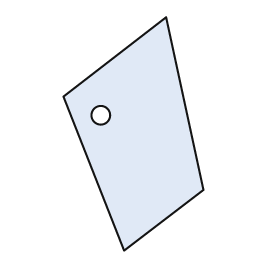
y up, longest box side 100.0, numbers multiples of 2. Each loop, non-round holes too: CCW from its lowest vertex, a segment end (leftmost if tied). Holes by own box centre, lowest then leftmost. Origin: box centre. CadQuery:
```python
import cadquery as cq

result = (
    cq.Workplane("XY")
    .moveTo(-4.0, -50.0)
    .lineTo(30.0, -24.0)
    .lineTo(14.0, 50.0)
    .lineTo(-30.0, 16.0)
    .close()
    .moveTo(-14.0, 8.0)
    .circle(4.0)
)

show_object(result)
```